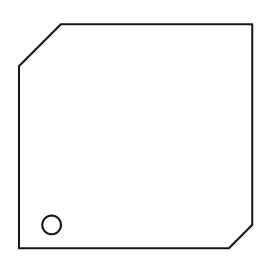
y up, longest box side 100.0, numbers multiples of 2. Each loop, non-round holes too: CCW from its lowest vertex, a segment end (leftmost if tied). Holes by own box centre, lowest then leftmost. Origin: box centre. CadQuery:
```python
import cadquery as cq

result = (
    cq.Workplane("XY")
    .moveTo(-50.0, -48.0)
    .lineTo(40.0, -48.0)
    .lineTo(50.0, -38.0)
    .lineTo(50.0, 48.0)
    .lineTo(-32.0, 48.0)
    .lineTo(-50.0, 30.0)
    .close()
    .moveTo(-36.0, -38.0)
    .circle(4.0)
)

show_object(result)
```